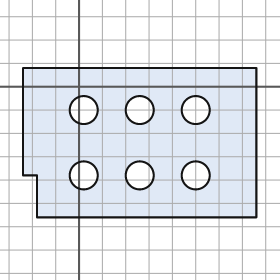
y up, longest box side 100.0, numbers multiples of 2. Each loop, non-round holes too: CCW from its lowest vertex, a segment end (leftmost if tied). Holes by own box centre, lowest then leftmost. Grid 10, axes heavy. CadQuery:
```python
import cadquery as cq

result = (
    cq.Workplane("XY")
    .moveTo(-18.0, -56.0)
    .lineTo(76.0, -56.0)
    .lineTo(76.0, 8.0)
    .lineTo(-24.0, 8.0)
    .lineTo(-24.0, -38.0)
    .lineTo(-18.0, -38.0)
    .close()
    .moveTo(2.0, -38.0)
    .circle(6.0)
    .moveTo(26.0, -38.0)
    .circle(6.0)
    .moveTo(50.0, -38.0)
    .circle(6.0)
    .moveTo(2.0, -10.0)
    .circle(6.0)
    .moveTo(26.0, -10.0)
    .circle(6.0)
    .moveTo(50.0, -10.0)
    .circle(6.0)
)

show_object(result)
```